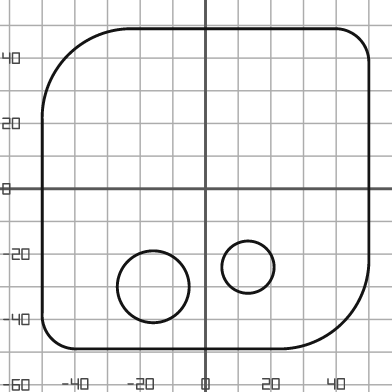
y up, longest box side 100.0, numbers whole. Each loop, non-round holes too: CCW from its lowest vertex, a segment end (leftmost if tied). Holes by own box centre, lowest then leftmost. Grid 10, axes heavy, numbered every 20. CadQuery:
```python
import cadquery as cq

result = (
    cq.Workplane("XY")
    .moveTo(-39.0, -49.0)
    .lineTo(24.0, -49.0)
    .threePointArc((42.0, -41.0), (50.0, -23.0))
    .lineTo(50.0, 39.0)
    .threePointArc((47.0, 46.0), (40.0, 49.0))
    .lineTo(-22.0, 49.0)
    .threePointArc((-42.0, 41.0), (-50.0, 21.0))
    .lineTo(-50.0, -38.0)
    .threePointArc((-47.0, -46.0), (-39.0, -49.0))
    .close()
    .moveTo(-16.0, -30.0)
    .circle(11.0)
    .moveTo(13.0, -24.0)
    .circle(8.0)
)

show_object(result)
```